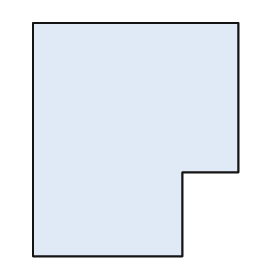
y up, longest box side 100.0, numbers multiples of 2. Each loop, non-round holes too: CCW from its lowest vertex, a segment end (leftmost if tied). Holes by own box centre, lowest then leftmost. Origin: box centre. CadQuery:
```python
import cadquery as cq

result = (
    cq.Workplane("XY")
    .moveTo(-44.0, -50.0)
    .lineTo(20.0, -50.0)
    .lineTo(20.0, -14.0)
    .lineTo(44.0, -14.0)
    .lineTo(44.0, 50.0)
    .lineTo(-44.0, 50.0)
    .close()
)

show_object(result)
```